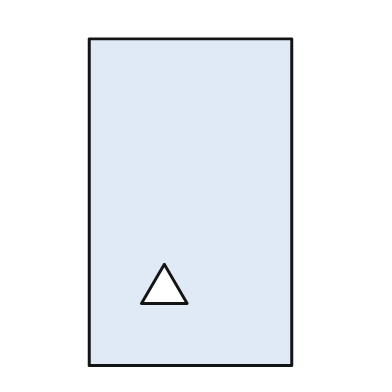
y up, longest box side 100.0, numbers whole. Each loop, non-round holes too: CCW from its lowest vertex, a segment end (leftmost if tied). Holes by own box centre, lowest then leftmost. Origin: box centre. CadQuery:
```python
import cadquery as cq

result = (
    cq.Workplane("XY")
    .moveTo(-31.0, -50.0)
    .lineTo(31.0, -50.0)
    .lineTo(31.0, 50.0)
    .lineTo(-31.0, 50.0)
    .close()
    .moveTo(-15.0, -31.0)
    .lineTo(-1.0, -31.0)
    .lineTo(-8.0, -19.0)
    .close()
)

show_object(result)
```